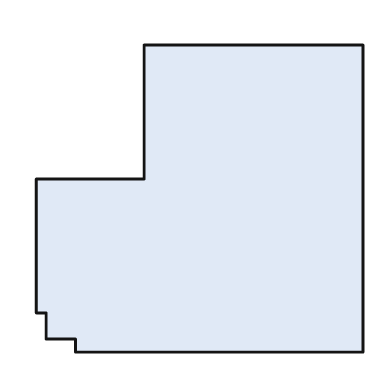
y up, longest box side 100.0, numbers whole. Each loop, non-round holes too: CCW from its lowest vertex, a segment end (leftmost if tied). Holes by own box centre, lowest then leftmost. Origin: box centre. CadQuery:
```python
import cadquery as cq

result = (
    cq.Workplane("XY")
    .moveTo(-38.0, -47.0)
    .lineTo(50.0, -47.0)
    .lineTo(50.0, 47.0)
    .lineTo(-17.0, 47.0)
    .lineTo(-17.0, 6.0)
    .lineTo(-50.0, 6.0)
    .lineTo(-50.0, -35.0)
    .lineTo(-47.0, -35.0)
    .lineTo(-47.0, -43.0)
    .lineTo(-38.0, -43.0)
    .close()
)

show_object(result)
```